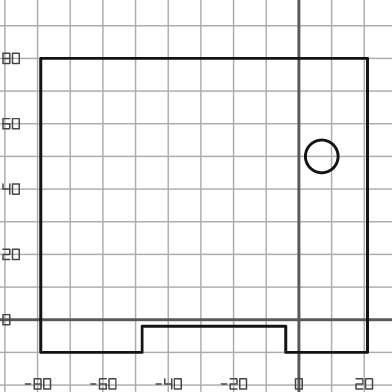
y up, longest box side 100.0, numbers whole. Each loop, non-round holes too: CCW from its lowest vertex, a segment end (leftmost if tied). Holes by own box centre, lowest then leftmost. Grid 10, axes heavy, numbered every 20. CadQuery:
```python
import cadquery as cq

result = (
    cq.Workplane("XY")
    .moveTo(-79.0, -10.0)
    .lineTo(-48.0, -10.0)
    .lineTo(-48.0, -2.0)
    .lineTo(-4.0, -2.0)
    .lineTo(-4.0, -10.0)
    .lineTo(21.0, -10.0)
    .lineTo(21.0, 80.0)
    .lineTo(-79.0, 80.0)
    .close()
    .moveTo(7.0, 50.0)
    .circle(5.0)
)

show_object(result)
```